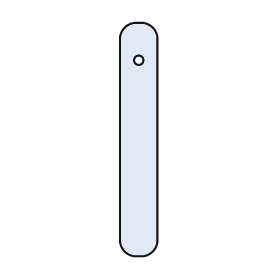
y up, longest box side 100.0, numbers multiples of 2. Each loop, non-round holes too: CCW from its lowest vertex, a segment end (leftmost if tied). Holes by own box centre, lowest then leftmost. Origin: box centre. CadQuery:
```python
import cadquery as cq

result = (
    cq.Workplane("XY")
    .moveTo(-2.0, -50.0)
    .lineTo(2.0, -50.0)
    .threePointArc((6.0, -48.0), (8.0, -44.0))
    .lineTo(8.0, 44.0)
    .threePointArc((6.0, 48.0), (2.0, 50.0))
    .lineTo(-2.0, 50.0)
    .threePointArc((-6.0, 48.0), (-8.0, 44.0))
    .lineTo(-8.0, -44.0)
    .threePointArc((-6.0, -48.0), (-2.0, -50.0))
    .close()
    .moveTo(0.0, 34.0)
    .circle(2.0)
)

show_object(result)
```